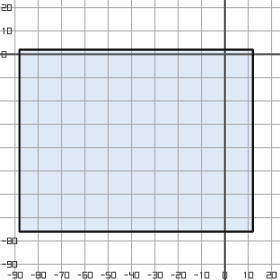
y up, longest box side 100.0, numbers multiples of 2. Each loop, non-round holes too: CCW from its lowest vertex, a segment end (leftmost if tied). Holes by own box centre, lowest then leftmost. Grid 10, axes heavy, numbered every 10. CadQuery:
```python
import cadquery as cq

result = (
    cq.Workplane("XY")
    .moveTo(-88.0, -76.0)
    .lineTo(12.0, -76.0)
    .lineTo(12.0, 2.0)
    .lineTo(-88.0, 2.0)
    .close()
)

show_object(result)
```